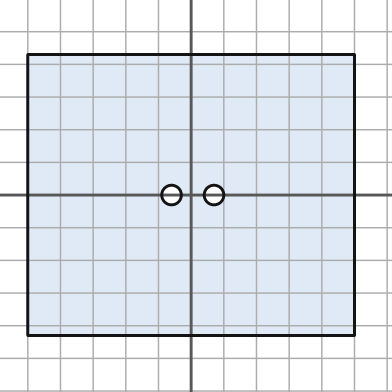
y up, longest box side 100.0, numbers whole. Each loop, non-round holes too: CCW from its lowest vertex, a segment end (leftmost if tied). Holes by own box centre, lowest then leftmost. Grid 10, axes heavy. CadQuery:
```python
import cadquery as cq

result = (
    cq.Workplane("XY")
    .moveTo(-50.0, -43.0)
    .lineTo(50.0, -43.0)
    .lineTo(50.0, 43.0)
    .lineTo(-50.0, 43.0)
    .close()
    .moveTo(-6.0, 0.0)
    .circle(3.0)
    .moveTo(7.0, 0.0)
    .circle(3.0)
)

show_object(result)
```